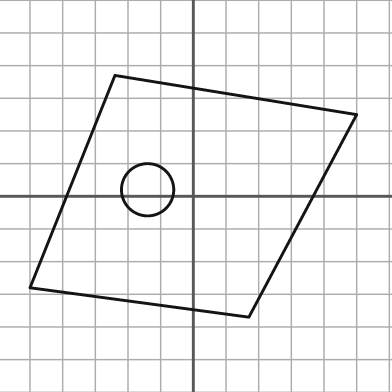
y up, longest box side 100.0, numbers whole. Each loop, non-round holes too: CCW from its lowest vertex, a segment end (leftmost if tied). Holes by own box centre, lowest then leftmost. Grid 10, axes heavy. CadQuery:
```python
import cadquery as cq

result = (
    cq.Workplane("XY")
    .moveTo(17.0, -37.0)
    .lineTo(50.0, 25.0)
    .lineTo(-24.0, 37.0)
    .lineTo(-50.0, -28.0)
    .close()
    .moveTo(-14.0, 2.0)
    .circle(8.0)
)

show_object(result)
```